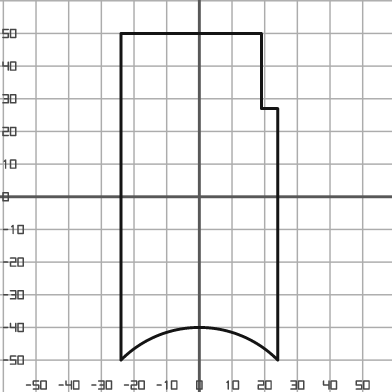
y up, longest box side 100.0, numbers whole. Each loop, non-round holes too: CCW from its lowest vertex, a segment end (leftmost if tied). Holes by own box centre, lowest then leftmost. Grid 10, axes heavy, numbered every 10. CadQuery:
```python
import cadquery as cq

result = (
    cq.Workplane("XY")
    .moveTo(-24.0, -50.0)
    .threePointArc((0.0, -40.0), (24.0, -50.0))
    .lineTo(24.0, 27.0)
    .lineTo(19.0, 27.0)
    .lineTo(19.0, 50.0)
    .lineTo(-24.0, 50.0)
    .close()
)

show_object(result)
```